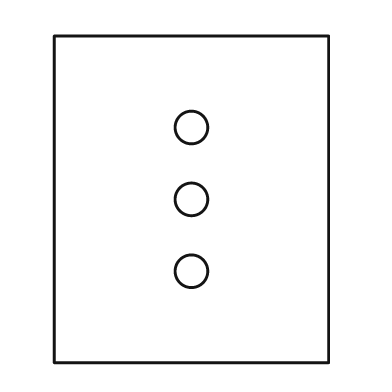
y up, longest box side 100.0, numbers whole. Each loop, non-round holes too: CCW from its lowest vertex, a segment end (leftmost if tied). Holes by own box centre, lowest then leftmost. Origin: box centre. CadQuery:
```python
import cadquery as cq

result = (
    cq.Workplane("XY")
    .moveTo(-42.0, -50.0)
    .lineTo(42.0, -50.0)
    .lineTo(42.0, 50.0)
    .lineTo(-42.0, 50.0)
    .close()
    .moveTo(0.0, -22.0)
    .circle(5.0)
    .moveTo(0.0, 0.0)
    .circle(5.0)
    .moveTo(0.0, 22.0)
    .circle(5.0)
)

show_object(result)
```